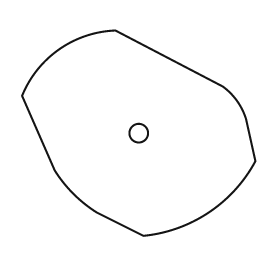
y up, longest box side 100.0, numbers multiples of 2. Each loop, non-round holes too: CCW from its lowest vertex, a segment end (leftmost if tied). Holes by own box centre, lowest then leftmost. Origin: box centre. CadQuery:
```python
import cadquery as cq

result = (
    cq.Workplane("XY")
    .moveTo(2.0, -44.0)
    .threePointArc((30.0, -34.0), (50.0, -12.0))
    .lineTo(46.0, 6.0)
    .threePointArc((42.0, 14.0), (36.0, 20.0))
    .lineTo(-10.0, 44.0)
    .threePointArc((-34.0, 36.0), (-50.0, 16.0))
    .lineTo(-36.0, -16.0)
    .threePointArc((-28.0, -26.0), (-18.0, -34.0))
    .close()
    .moveTo(0.0, 0.0)
    .circle(4.0)
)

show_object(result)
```